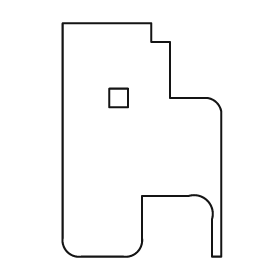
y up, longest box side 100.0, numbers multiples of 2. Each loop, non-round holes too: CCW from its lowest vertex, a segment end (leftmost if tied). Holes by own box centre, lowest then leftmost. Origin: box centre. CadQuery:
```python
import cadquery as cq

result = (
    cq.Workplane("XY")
    .moveTo(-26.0, -50.0)
    .lineTo(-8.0, -50.0)
    .threePointArc((-2.0, -48.0), (0.0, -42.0))
    .lineTo(0.0, -24.0)
    .lineTo(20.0, -24.0)
    .threePointArc((28.0, -26.0), (30.0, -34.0))
    .lineTo(30.0, -50.0)
    .lineTo(34.0, -50.0)
    .lineTo(34.0, 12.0)
    .threePointArc((32.0, 16.0), (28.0, 18.0))
    .lineTo(12.0, 18.0)
    .lineTo(12.0, 42.0)
    .lineTo(4.0, 42.0)
    .lineTo(4.0, 50.0)
    .lineTo(-34.0, 50.0)
    .lineTo(-34.0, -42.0)
    .threePointArc((-32.0, -48.0), (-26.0, -50.0))
    .close()
    .moveTo(-14.0, 14.0)
    .lineTo(-6.0, 14.0)
    .lineTo(-6.0, 22.0)
    .lineTo(-14.0, 22.0)
    .close()
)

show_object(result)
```